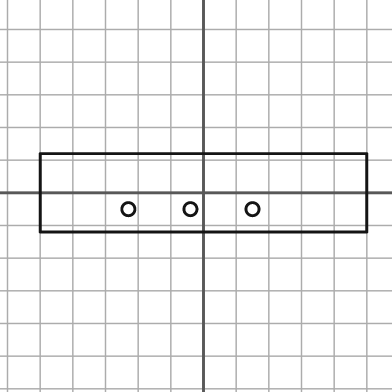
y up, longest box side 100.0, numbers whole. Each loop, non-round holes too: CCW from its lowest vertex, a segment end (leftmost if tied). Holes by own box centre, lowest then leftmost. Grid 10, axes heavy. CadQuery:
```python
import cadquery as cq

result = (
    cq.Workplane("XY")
    .moveTo(-50.0, -12.0)
    .lineTo(50.0, -12.0)
    .lineTo(50.0, 12.0)
    .lineTo(-50.0, 12.0)
    .close()
    .moveTo(-23.0, -5.0)
    .circle(2.0)
    .moveTo(-4.0, -5.0)
    .circle(2.0)
    .moveTo(15.0, -5.0)
    .circle(2.0)
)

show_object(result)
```